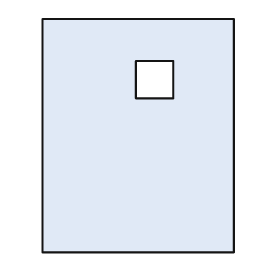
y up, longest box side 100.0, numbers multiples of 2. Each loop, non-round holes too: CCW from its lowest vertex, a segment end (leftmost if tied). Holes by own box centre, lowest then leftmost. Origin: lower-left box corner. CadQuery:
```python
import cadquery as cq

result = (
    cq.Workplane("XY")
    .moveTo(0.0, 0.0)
    .lineTo(82.0, 0.0)
    .lineTo(82.0, 100.0)
    .lineTo(0.0, 100.0)
    .close()
    .moveTo(40.0, 66.0)
    .lineTo(56.0, 66.0)
    .lineTo(56.0, 82.0)
    .lineTo(40.0, 82.0)
    .close()
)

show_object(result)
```